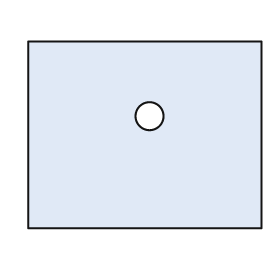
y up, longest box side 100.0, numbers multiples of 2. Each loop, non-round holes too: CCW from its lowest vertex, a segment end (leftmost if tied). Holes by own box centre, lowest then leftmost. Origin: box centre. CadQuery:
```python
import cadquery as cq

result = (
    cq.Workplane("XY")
    .moveTo(-50.0, -40.0)
    .lineTo(50.0, -40.0)
    .lineTo(50.0, 40.0)
    .lineTo(-50.0, 40.0)
    .close()
    .moveTo(2.0, 8.0)
    .circle(6.0)
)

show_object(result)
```